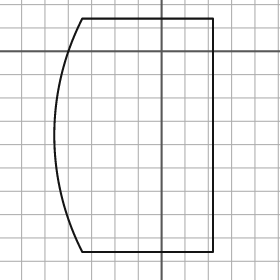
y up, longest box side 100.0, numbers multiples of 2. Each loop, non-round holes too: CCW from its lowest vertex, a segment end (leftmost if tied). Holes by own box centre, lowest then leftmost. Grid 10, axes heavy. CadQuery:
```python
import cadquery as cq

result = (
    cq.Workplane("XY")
    .moveTo(-34.0, -86.0)
    .lineTo(22.0, -86.0)
    .lineTo(22.0, 14.0)
    .lineTo(-34.0, 14.0)
    .threePointArc((-46.0, -36.0), (-34.0, -86.0))
    .close()
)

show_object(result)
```